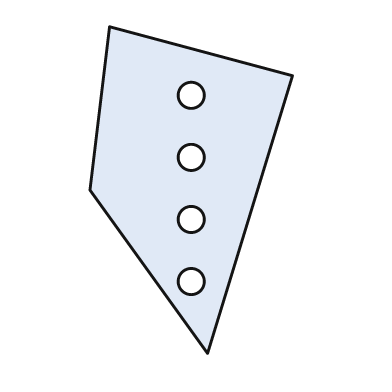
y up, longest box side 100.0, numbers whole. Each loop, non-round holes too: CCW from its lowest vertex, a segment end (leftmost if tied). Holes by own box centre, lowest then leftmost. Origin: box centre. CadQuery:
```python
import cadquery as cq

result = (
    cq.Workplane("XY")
    .moveTo(5.0, -50.0)
    .lineTo(31.0, 35.0)
    .lineTo(-25.0, 50.0)
    .lineTo(-31.0, 0.0)
    .close()
    .moveTo(0.0, -28.0)
    .circle(4.0)
    .moveTo(0.0, -9.0)
    .circle(4.0)
    .moveTo(0.0, 10.0)
    .circle(4.0)
    .moveTo(0.0, 29.0)
    .circle(4.0)
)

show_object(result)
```